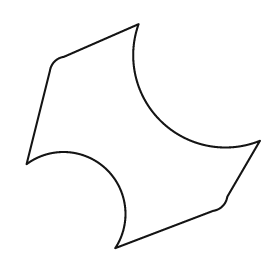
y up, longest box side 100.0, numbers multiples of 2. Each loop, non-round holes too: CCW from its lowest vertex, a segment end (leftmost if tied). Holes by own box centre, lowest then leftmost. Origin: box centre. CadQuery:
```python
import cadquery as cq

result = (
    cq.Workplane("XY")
    .moveTo(-12.0, -48.0)
    .lineTo(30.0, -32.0)
    .threePointArc((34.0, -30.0), (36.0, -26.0))
    .lineTo(50.0, -2.0)
    .threePointArc((8.0, 6.0), (-2.0, 48.0))
    .lineTo(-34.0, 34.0)
    .threePointArc((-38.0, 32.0), (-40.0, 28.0))
    .lineTo(-50.0, -12.0)
    .threePointArc((-16.0, -14.0), (-12.0, -48.0))
    .close()
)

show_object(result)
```